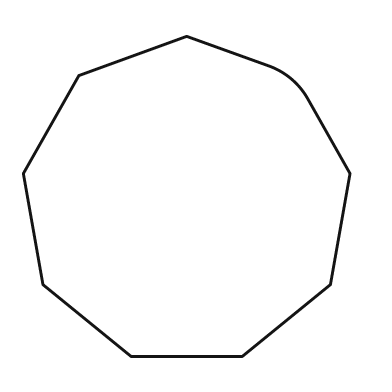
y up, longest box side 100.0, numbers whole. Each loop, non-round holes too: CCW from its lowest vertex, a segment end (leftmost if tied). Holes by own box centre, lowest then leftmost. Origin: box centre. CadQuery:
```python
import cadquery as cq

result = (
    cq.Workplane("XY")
    .moveTo(-17.0, -49.0)
    .lineTo(17.0, -49.0)
    .lineTo(44.0, -27.0)
    .lineTo(50.0, 7.0)
    .lineTo(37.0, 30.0)
    .threePointArc((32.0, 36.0), (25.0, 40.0))
    .lineTo(0.0, 49.0)
    .lineTo(-33.0, 37.0)
    .lineTo(-50.0, 7.0)
    .lineTo(-44.0, -27.0)
    .close()
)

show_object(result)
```